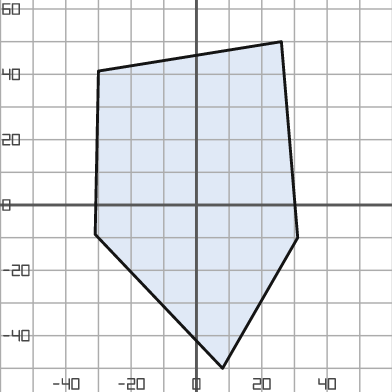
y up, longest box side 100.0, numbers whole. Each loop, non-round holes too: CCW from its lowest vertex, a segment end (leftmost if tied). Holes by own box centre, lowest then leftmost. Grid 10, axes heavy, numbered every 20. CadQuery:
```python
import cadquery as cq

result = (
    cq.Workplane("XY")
    .moveTo(8.0, -50.0)
    .lineTo(31.0, -10.0)
    .lineTo(26.0, 50.0)
    .lineTo(-30.0, 41.0)
    .lineTo(-31.0, -9.0)
    .close()
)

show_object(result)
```